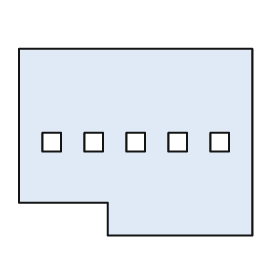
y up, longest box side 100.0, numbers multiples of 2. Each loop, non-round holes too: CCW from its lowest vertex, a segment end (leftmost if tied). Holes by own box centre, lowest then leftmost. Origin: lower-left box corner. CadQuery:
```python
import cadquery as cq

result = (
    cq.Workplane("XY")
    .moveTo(38.0, 0.0)
    .lineTo(100.0, 0.0)
    .lineTo(100.0, 80.0)
    .lineTo(0.0, 80.0)
    .lineTo(0.0, 14.0)
    .lineTo(38.0, 14.0)
    .close()
    .moveTo(10.0, 36.0)
    .lineTo(18.0, 36.0)
    .lineTo(18.0, 44.0)
    .lineTo(10.0, 44.0)
    .close()
    .moveTo(28.0, 36.0)
    .lineTo(36.0, 36.0)
    .lineTo(36.0, 44.0)
    .lineTo(28.0, 44.0)
    .close()
    .moveTo(46.0, 36.0)
    .lineTo(54.0, 36.0)
    .lineTo(54.0, 44.0)
    .lineTo(46.0, 44.0)
    .close()
    .moveTo(64.0, 36.0)
    .lineTo(72.0, 36.0)
    .lineTo(72.0, 44.0)
    .lineTo(64.0, 44.0)
    .close()
    .moveTo(82.0, 36.0)
    .lineTo(90.0, 36.0)
    .lineTo(90.0, 44.0)
    .lineTo(82.0, 44.0)
    .close()
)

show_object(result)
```